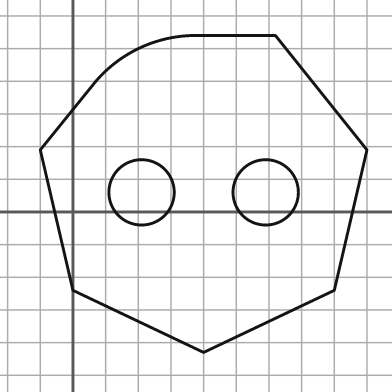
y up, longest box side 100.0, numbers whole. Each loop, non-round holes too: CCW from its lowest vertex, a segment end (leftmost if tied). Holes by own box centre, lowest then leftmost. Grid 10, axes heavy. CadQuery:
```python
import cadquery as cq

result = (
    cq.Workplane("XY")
    .moveTo(40.0, -43.0)
    .lineTo(80.0, -24.0)
    .lineTo(90.0, 19.0)
    .lineTo(62.0, 54.0)
    .lineTo(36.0, 54.0)
    .threePointArc((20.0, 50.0), (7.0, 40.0))
    .lineTo(-10.0, 19.0)
    .lineTo(0.0, -24.0)
    .close()
    .moveTo(21.0, 6.0)
    .circle(10.0)
    .moveTo(59.0, 6.0)
    .circle(10.0)
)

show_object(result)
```